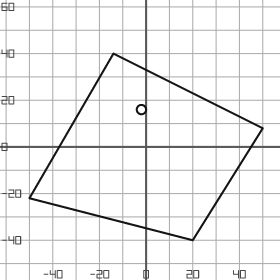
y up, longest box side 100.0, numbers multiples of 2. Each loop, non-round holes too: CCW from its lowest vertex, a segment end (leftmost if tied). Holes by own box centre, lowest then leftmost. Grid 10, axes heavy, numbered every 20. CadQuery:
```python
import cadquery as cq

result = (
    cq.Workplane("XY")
    .moveTo(20.0, -40.0)
    .lineTo(50.0, 8.0)
    .lineTo(-14.0, 40.0)
    .lineTo(-50.0, -22.0)
    .close()
    .moveTo(-2.0, 16.0)
    .circle(2.0)
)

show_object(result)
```